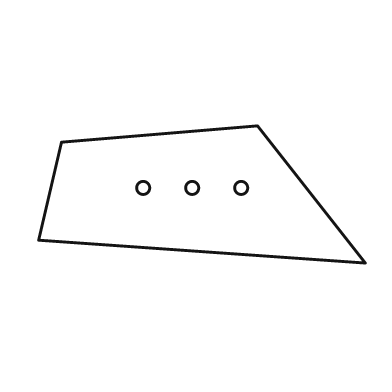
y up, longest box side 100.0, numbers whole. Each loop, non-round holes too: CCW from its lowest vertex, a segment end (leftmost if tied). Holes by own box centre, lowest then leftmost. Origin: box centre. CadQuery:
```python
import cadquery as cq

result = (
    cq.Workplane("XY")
    .moveTo(50.0, -21.0)
    .lineTo(17.0, 21.0)
    .lineTo(-43.0, 16.0)
    .lineTo(-50.0, -14.0)
    .close()
    .moveTo(-18.0, 2.0)
    .circle(2.0)
    .moveTo(-3.0, 2.0)
    .circle(2.0)
    .moveTo(12.0, 2.0)
    .circle(2.0)
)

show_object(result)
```